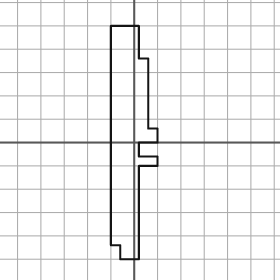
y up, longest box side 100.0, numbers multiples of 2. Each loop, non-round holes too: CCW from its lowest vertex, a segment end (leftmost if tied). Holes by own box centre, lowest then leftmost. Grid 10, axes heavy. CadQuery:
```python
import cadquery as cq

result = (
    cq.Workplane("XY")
    .moveTo(-6.0, -50.0)
    .lineTo(2.0, -50.0)
    .lineTo(2.0, -10.0)
    .lineTo(10.0, -10.0)
    .lineTo(10.0, -6.0)
    .lineTo(2.0, -6.0)
    .lineTo(2.0, 0.0)
    .lineTo(10.0, 0.0)
    .lineTo(10.0, 6.0)
    .lineTo(6.0, 6.0)
    .lineTo(6.0, 36.0)
    .lineTo(2.0, 36.0)
    .lineTo(2.0, 50.0)
    .lineTo(-10.0, 50.0)
    .lineTo(-10.0, -44.0)
    .lineTo(-6.0, -44.0)
    .close()
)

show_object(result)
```